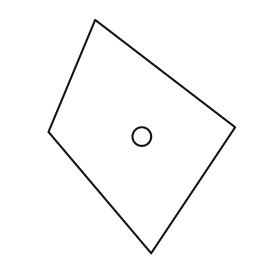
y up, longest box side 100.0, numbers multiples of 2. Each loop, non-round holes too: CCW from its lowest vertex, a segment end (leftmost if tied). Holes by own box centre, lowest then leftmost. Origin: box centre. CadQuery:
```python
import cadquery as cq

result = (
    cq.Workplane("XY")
    .moveTo(4.0, -50.0)
    .lineTo(40.0, 4.0)
    .lineTo(-20.0, 50.0)
    .lineTo(-40.0, 2.0)
    .close()
    .moveTo(0.0, 0.0)
    .circle(4.0)
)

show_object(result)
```